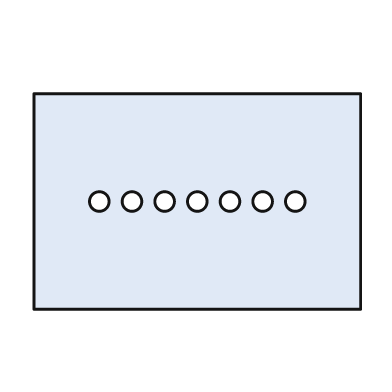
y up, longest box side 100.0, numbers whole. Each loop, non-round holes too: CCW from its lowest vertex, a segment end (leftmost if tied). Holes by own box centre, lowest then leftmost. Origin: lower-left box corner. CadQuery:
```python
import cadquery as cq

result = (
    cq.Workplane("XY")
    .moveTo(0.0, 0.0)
    .lineTo(100.0, 0.0)
    .lineTo(100.0, 66.0)
    .lineTo(0.0, 66.0)
    .close()
    .moveTo(20.0, 33.0)
    .circle(3.0)
    .moveTo(30.0, 33.0)
    .circle(3.0)
    .moveTo(40.0, 33.0)
    .circle(3.0)
    .moveTo(50.0, 33.0)
    .circle(3.0)
    .moveTo(60.0, 33.0)
    .circle(3.0)
    .moveTo(70.0, 33.0)
    .circle(3.0)
    .moveTo(80.0, 33.0)
    .circle(3.0)
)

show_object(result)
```